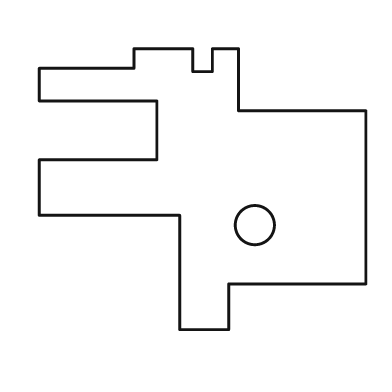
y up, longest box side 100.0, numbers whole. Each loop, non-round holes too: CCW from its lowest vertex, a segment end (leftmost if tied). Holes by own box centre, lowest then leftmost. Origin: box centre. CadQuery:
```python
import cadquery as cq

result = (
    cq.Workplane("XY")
    .moveTo(-7.0, -43.0)
    .lineTo(8.0, -43.0)
    .lineTo(8.0, -29.0)
    .lineTo(50.0, -29.0)
    .lineTo(50.0, 24.0)
    .lineTo(11.0, 24.0)
    .lineTo(11.0, 43.0)
    .lineTo(3.0, 43.0)
    .lineTo(3.0, 36.0)
    .lineTo(-3.0, 36.0)
    .lineTo(-3.0, 43.0)
    .lineTo(-21.0, 43.0)
    .lineTo(-21.0, 37.0)
    .lineTo(-50.0, 37.0)
    .lineTo(-50.0, 27.0)
    .lineTo(-14.0, 27.0)
    .lineTo(-14.0, 9.0)
    .lineTo(-50.0, 9.0)
    .lineTo(-50.0, -8.0)
    .lineTo(-7.0, -8.0)
    .close()
    .moveTo(16.0, -11.0)
    .circle(6.0)
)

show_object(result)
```